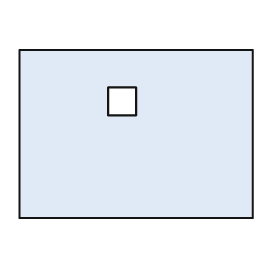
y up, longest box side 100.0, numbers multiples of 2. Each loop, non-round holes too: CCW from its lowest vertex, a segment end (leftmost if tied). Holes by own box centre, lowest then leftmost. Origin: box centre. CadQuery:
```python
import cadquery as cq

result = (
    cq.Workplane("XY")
    .moveTo(-50.0, -36.0)
    .lineTo(50.0, -36.0)
    .lineTo(50.0, 36.0)
    .lineTo(-50.0, 36.0)
    .close()
    .moveTo(-12.0, 8.0)
    .lineTo(0.0, 8.0)
    .lineTo(0.0, 20.0)
    .lineTo(-12.0, 20.0)
    .close()
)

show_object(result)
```